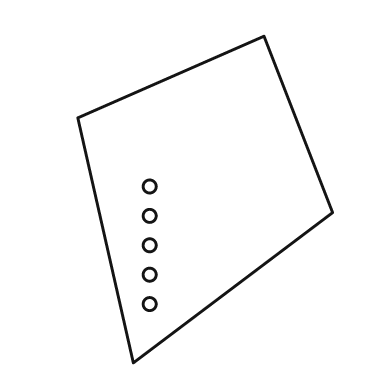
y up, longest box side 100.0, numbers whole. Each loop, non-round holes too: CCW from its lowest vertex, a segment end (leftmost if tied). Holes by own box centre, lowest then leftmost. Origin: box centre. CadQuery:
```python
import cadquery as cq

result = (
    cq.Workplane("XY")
    .moveTo(-22.0, -50.0)
    .lineTo(39.0, -4.0)
    .lineTo(18.0, 50.0)
    .lineTo(-39.0, 25.0)
    .close()
    .moveTo(-17.0, -32.0)
    .circle(2.0)
    .moveTo(-17.0, -23.0)
    .circle(2.0)
    .moveTo(-17.0, -14.0)
    .circle(2.0)
    .moveTo(-17.0, -5.0)
    .circle(2.0)
    .moveTo(-17.0, 4.0)
    .circle(2.0)
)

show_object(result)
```